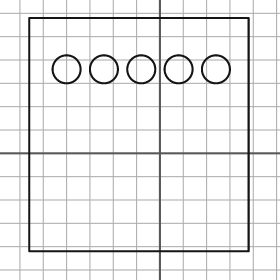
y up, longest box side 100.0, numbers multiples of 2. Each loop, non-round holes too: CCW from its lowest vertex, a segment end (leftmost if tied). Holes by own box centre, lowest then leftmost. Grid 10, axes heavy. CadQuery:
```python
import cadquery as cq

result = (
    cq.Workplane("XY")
    .moveTo(-56.0, -42.0)
    .lineTo(38.0, -42.0)
    .lineTo(38.0, 58.0)
    .lineTo(-56.0, 58.0)
    .close()
    .moveTo(-40.0, 36.0)
    .circle(6.0)
    .moveTo(-24.0, 36.0)
    .circle(6.0)
    .moveTo(-8.0, 36.0)
    .circle(6.0)
    .moveTo(8.0, 36.0)
    .circle(6.0)
    .moveTo(24.0, 36.0)
    .circle(6.0)
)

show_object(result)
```